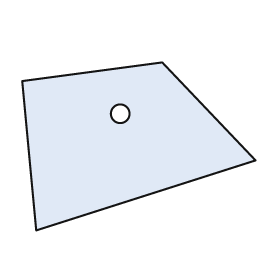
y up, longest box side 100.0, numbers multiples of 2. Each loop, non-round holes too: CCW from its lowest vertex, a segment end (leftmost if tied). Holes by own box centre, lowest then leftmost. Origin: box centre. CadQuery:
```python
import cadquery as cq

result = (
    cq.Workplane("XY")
    .moveTo(-44.0, -36.0)
    .lineTo(50.0, -6.0)
    .lineTo(10.0, 36.0)
    .lineTo(-50.0, 28.0)
    .close()
    .moveTo(-8.0, 14.0)
    .circle(4.0)
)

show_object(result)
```